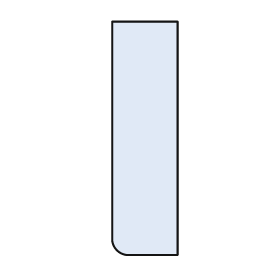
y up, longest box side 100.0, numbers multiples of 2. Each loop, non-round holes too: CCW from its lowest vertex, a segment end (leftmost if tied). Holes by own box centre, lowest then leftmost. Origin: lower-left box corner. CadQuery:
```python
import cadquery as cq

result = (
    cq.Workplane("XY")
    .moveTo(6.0, 0.0)
    .lineTo(28.0, 0.0)
    .lineTo(28.0, 100.0)
    .lineTo(0.0, 100.0)
    .lineTo(0.0, 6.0)
    .threePointArc((2.0, 2.0), (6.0, 0.0))
    .close()
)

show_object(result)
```